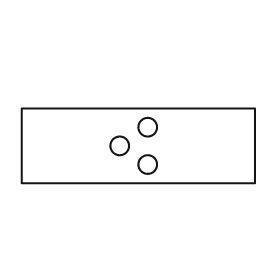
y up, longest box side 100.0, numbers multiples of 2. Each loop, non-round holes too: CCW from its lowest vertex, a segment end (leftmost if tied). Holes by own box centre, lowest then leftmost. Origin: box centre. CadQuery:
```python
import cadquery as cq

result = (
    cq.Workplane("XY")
    .moveTo(-50.0, -16.0)
    .lineTo(50.0, -16.0)
    .lineTo(50.0, 16.0)
    .lineTo(-50.0, 16.0)
    .close()
    .moveTo(4.0, -8.0)
    .circle(4.0)
    .moveTo(-8.0, 0.0)
    .circle(4.0)
    .moveTo(4.0, 8.0)
    .circle(4.0)
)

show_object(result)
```